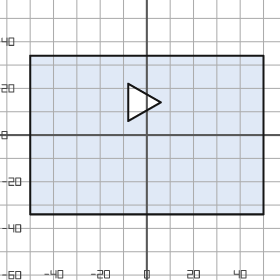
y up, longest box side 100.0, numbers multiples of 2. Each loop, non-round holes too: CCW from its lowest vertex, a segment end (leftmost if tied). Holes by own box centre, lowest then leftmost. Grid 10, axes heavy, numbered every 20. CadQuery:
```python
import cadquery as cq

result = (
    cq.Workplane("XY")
    .moveTo(-50.0, -34.0)
    .lineTo(50.0, -34.0)
    .lineTo(50.0, 34.0)
    .lineTo(-50.0, 34.0)
    .close()
    .moveTo(-8.0, 6.0)
    .lineTo(6.0, 14.0)
    .lineTo(-8.0, 22.0)
    .close()
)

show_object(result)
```